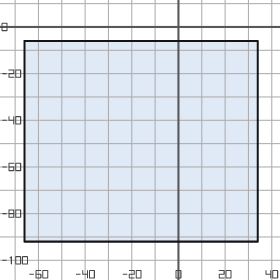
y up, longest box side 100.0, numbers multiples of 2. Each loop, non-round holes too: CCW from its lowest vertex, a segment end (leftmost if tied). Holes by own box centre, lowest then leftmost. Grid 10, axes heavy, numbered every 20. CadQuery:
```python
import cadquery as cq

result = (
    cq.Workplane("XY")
    .moveTo(-66.0, -92.0)
    .lineTo(34.0, -92.0)
    .lineTo(34.0, -6.0)
    .lineTo(-66.0, -6.0)
    .close()
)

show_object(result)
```